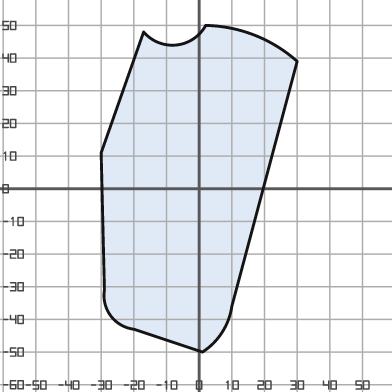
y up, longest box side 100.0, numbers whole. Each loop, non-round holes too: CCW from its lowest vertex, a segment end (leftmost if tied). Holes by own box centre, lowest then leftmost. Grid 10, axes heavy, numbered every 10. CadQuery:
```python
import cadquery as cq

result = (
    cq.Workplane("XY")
    .moveTo(1.0, -50.0)
    .threePointArc((7.0, -44.0), (10.0, -36.0))
    .lineTo(30.0, 39.0)
    .threePointArc((17.0, 47.0), (2.0, 50.0))
    .threePointArc((-7.0, 44.0), (-17.0, 48.0))
    .lineTo(-30.0, 11.0)
    .lineTo(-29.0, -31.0)
    .threePointArc((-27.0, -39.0), (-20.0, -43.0))
    .close()
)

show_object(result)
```